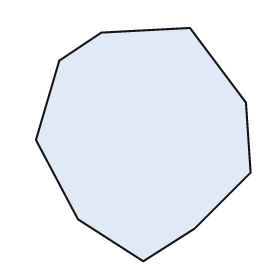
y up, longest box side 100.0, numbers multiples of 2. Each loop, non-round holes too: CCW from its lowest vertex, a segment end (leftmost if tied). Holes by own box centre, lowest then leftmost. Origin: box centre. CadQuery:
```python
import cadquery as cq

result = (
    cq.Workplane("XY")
    .moveTo(0.0, -50.0)
    .lineTo(22.0, -36.0)
    .lineTo(46.0, -12.0)
    .lineTo(44.0, 18.0)
    .lineTo(20.0, 50.0)
    .lineTo(-18.0, 48.0)
    .lineTo(-36.0, 36.0)
    .lineTo(-46.0, 2.0)
    .lineTo(-28.0, -32.0)
    .close()
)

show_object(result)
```